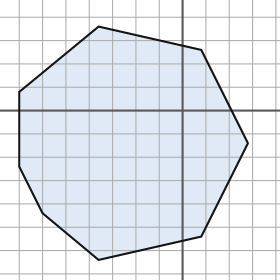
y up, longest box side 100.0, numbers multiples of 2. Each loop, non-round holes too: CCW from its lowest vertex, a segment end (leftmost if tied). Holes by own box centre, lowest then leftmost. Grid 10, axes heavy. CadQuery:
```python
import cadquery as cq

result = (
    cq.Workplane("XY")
    .moveTo(-36.0, -64.0)
    .lineTo(8.0, -54.0)
    .lineTo(28.0, -14.0)
    .lineTo(8.0, 26.0)
    .lineTo(-36.0, 36.0)
    .lineTo(-70.0, 8.0)
    .lineTo(-70.0, -24.0)
    .lineTo(-60.0, -44.0)
    .close()
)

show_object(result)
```